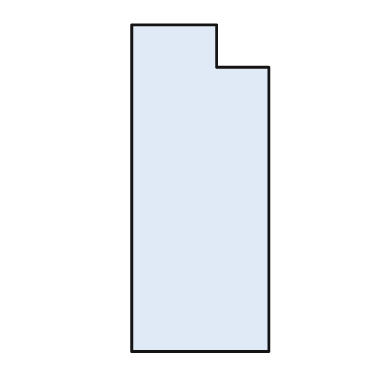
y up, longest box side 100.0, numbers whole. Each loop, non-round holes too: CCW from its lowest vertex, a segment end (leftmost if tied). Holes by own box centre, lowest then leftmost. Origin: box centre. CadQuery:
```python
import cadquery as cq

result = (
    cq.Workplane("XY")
    .moveTo(-21.0, -50.0)
    .lineTo(21.0, -50.0)
    .lineTo(21.0, 37.0)
    .lineTo(5.0, 37.0)
    .lineTo(5.0, 50.0)
    .lineTo(-21.0, 50.0)
    .close()
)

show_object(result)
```